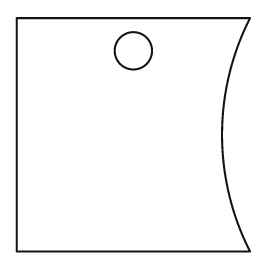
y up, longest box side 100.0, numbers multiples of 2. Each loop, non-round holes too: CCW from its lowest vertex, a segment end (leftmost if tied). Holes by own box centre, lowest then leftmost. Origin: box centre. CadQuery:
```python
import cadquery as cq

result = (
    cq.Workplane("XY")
    .moveTo(-50.0, -50.0)
    .lineTo(50.0, -50.0)
    .threePointArc((38.0, 0.0), (50.0, 50.0))
    .lineTo(-50.0, 50.0)
    .close()
    .moveTo(0.0, 36.0)
    .circle(8.0)
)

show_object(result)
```